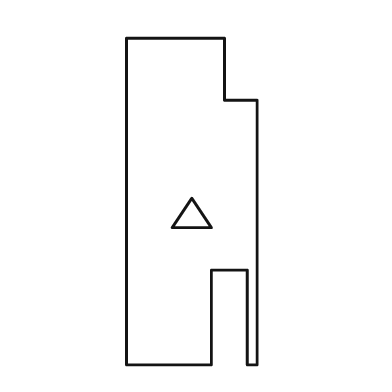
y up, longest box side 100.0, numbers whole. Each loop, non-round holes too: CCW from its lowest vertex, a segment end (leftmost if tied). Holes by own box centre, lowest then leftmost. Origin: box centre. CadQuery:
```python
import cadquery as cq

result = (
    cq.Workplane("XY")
    .moveTo(-20.0, -50.0)
    .lineTo(6.0, -50.0)
    .lineTo(6.0, -21.0)
    .lineTo(17.0, -21.0)
    .lineTo(17.0, -50.0)
    .lineTo(20.0, -50.0)
    .lineTo(20.0, 31.0)
    .lineTo(10.0, 31.0)
    .lineTo(10.0, 50.0)
    .lineTo(-20.0, 50.0)
    .close()
    .moveTo(-6.0, -8.0)
    .lineTo(6.0, -8.0)
    .lineTo(0.0, 1.0)
    .close()
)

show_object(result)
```